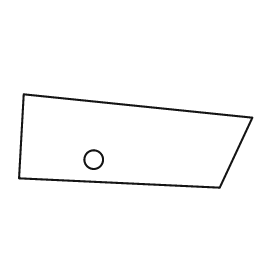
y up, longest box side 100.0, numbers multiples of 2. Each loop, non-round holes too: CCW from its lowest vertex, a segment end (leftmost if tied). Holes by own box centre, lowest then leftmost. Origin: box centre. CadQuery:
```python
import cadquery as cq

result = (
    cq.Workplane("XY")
    .moveTo(36.0, -20.0)
    .lineTo(50.0, 10.0)
    .lineTo(-48.0, 20.0)
    .lineTo(-50.0, -16.0)
    .close()
    .moveTo(-18.0, -8.0)
    .circle(4.0)
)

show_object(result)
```